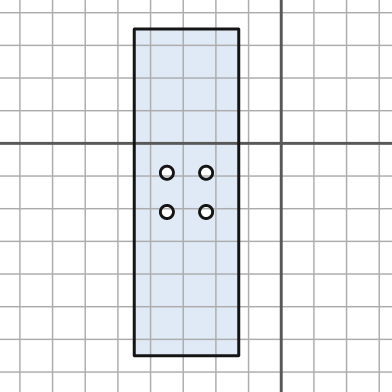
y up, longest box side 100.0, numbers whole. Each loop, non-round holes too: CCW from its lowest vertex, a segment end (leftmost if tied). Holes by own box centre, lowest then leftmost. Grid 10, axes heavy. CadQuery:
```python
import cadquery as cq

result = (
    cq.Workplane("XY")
    .moveTo(-45.0, -65.0)
    .lineTo(-13.0, -65.0)
    .lineTo(-13.0, 35.0)
    .lineTo(-45.0, 35.0)
    .close()
    .moveTo(-35.0, -21.0)
    .circle(2.0)
    .moveTo(-23.0, -21.0)
    .circle(2.0)
    .moveTo(-35.0, -9.0)
    .circle(2.0)
    .moveTo(-23.0, -9.0)
    .circle(2.0)
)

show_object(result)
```